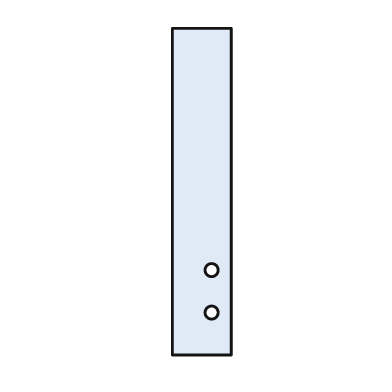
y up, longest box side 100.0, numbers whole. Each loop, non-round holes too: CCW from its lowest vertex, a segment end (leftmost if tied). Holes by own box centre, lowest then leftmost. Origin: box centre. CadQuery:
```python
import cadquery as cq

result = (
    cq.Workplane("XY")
    .moveTo(-9.0, -50.0)
    .lineTo(9.0, -50.0)
    .lineTo(9.0, 50.0)
    .lineTo(-9.0, 50.0)
    .close()
    .moveTo(3.0, -37.0)
    .circle(2.0)
    .moveTo(3.0, -24.0)
    .circle(2.0)
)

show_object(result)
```